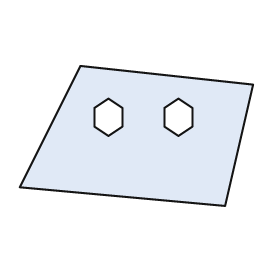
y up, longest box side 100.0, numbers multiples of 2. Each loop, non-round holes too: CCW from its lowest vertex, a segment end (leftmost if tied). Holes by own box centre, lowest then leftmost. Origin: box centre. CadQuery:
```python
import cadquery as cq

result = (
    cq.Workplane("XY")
    .moveTo(38.0, -30.0)
    .lineTo(50.0, 22.0)
    .lineTo(-24.0, 30.0)
    .lineTo(-50.0, -22.0)
    .close()
    .moveTo(-12.0, 0.0)
    .lineTo(-6.0, 4.0)
    .lineTo(-6.0, 12.0)
    .lineTo(-12.0, 16.0)
    .lineTo(-18.0, 12.0)
    .lineTo(-18.0, 4.0)
    .close()
    .moveTo(18.0, 0.0)
    .lineTo(24.0, 4.0)
    .lineTo(24.0, 12.0)
    .lineTo(18.0, 16.0)
    .lineTo(12.0, 12.0)
    .lineTo(12.0, 4.0)
    .close()
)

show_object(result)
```